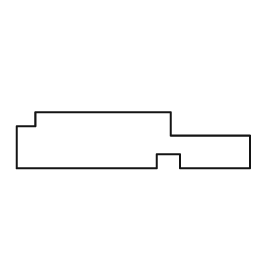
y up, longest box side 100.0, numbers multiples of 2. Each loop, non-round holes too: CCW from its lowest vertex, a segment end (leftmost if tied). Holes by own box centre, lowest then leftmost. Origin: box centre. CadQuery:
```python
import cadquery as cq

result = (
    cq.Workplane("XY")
    .moveTo(-50.0, -12.0)
    .lineTo(10.0, -12.0)
    .lineTo(10.0, -6.0)
    .lineTo(20.0, -6.0)
    .lineTo(20.0, -12.0)
    .lineTo(50.0, -12.0)
    .lineTo(50.0, 2.0)
    .lineTo(16.0, 2.0)
    .lineTo(16.0, 12.0)
    .lineTo(-42.0, 12.0)
    .lineTo(-42.0, 6.0)
    .lineTo(-50.0, 6.0)
    .close()
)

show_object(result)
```